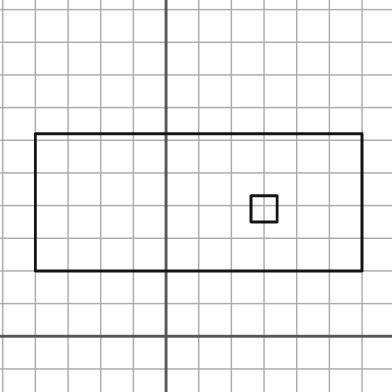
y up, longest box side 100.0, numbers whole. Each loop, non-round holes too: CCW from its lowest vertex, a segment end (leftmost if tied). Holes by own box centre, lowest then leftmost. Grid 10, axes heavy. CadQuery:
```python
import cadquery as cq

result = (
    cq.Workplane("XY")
    .moveTo(-40.0, 20.0)
    .lineTo(60.0, 20.0)
    .lineTo(60.0, 62.0)
    .lineTo(-40.0, 62.0)
    .close()
    .moveTo(26.0, 35.0)
    .lineTo(34.0, 35.0)
    .lineTo(34.0, 43.0)
    .lineTo(26.0, 43.0)
    .close()
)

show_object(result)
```